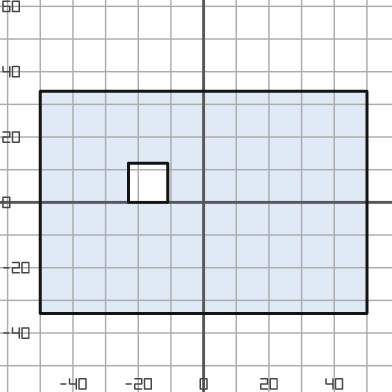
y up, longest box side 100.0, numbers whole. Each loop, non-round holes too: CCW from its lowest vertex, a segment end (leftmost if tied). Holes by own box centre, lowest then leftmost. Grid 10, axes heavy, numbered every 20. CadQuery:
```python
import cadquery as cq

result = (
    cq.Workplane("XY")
    .moveTo(-50.0, -34.0)
    .lineTo(50.0, -34.0)
    .lineTo(50.0, 34.0)
    .lineTo(-50.0, 34.0)
    .close()
    .moveTo(-23.0, 0.0)
    .lineTo(-11.0, 0.0)
    .lineTo(-11.0, 12.0)
    .lineTo(-23.0, 12.0)
    .close()
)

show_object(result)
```